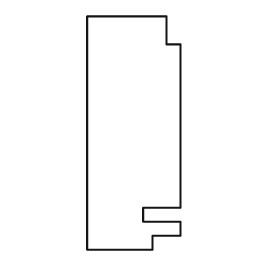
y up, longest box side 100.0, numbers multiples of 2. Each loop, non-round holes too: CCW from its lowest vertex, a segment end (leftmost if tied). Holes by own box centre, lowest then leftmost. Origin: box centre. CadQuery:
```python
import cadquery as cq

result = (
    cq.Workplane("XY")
    .moveTo(-20.0, -50.0)
    .lineTo(8.0, -50.0)
    .lineTo(8.0, -44.0)
    .lineTo(20.0, -44.0)
    .lineTo(20.0, -38.0)
    .lineTo(4.0, -38.0)
    .lineTo(4.0, -32.0)
    .lineTo(20.0, -32.0)
    .lineTo(20.0, 38.0)
    .lineTo(14.0, 38.0)
    .lineTo(14.0, 50.0)
    .lineTo(-20.0, 50.0)
    .close()
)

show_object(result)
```